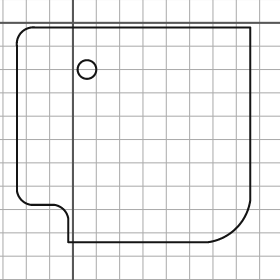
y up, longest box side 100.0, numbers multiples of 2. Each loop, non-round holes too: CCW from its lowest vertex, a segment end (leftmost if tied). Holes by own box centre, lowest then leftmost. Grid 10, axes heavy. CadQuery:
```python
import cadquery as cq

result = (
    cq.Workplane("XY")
    .moveTo(-2.0, -94.0)
    .lineTo(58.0, -94.0)
    .threePointArc((70.0, -88.0), (76.0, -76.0))
    .lineTo(76.0, -2.0)
    .lineTo(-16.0, -2.0)
    .threePointArc((-22.0, -4.0), (-24.0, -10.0))
    .lineTo(-24.0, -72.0)
    .threePointArc((-22.0, -76.0), (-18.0, -78.0))
    .lineTo(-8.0, -78.0)
    .threePointArc((-4.0, -80.0), (-2.0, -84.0))
    .close()
    .moveTo(6.0, -20.0)
    .circle(4.0)
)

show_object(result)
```